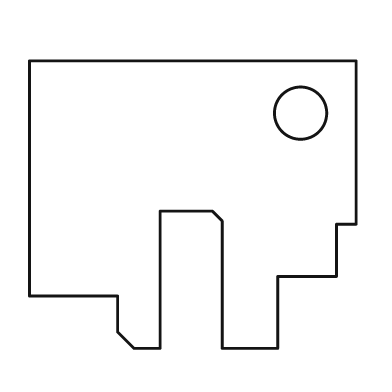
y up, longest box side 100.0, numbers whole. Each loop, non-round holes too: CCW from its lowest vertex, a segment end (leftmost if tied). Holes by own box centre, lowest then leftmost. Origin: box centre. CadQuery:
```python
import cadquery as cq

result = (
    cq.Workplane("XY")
    .moveTo(-18.0, -44.0)
    .lineTo(-10.0, -44.0)
    .lineTo(-10.0, -2.0)
    .lineTo(6.0, -2.0)
    .lineTo(9.0, -5.0)
    .lineTo(9.0, -44.0)
    .lineTo(26.0, -44.0)
    .lineTo(26.0, -22.0)
    .lineTo(44.0, -22.0)
    .lineTo(44.0, -6.0)
    .lineTo(50.0, -6.0)
    .lineTo(50.0, 44.0)
    .lineTo(-50.0, 44.0)
    .lineTo(-50.0, -28.0)
    .lineTo(-23.0, -28.0)
    .lineTo(-23.0, -39.0)
    .close()
    .moveTo(33.0, 28.0)
    .circle(8.0)
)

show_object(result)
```